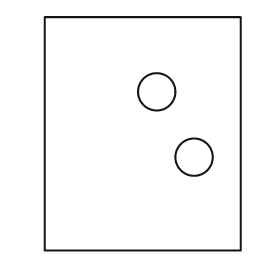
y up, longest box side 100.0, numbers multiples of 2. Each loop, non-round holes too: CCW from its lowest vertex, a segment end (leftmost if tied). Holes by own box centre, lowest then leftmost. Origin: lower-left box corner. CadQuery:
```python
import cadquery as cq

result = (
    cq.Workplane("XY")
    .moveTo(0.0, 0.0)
    .lineTo(84.0, 0.0)
    .lineTo(84.0, 100.0)
    .lineTo(0.0, 100.0)
    .close()
    .moveTo(64.0, 40.0)
    .circle(8.0)
    .moveTo(48.0, 68.0)
    .circle(8.0)
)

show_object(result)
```